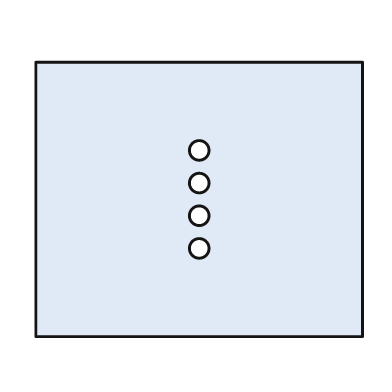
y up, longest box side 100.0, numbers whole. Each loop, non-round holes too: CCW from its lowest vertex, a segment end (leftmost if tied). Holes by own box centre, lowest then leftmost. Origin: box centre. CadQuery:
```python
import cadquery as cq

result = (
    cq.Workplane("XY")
    .moveTo(-50.0, -42.0)
    .lineTo(50.0, -42.0)
    .lineTo(50.0, 42.0)
    .lineTo(-50.0, 42.0)
    .close()
    .moveTo(0.0, -15.0)
    .circle(3.0)
    .moveTo(0.0, -5.0)
    .circle(3.0)
    .moveTo(0.0, 5.0)
    .circle(3.0)
    .moveTo(0.0, 15.0)
    .circle(3.0)
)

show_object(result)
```